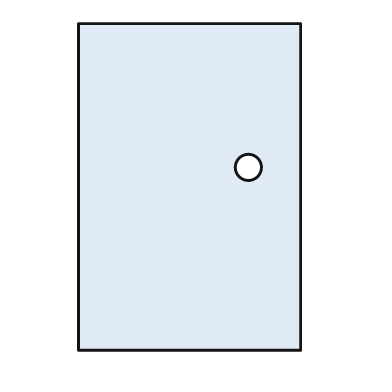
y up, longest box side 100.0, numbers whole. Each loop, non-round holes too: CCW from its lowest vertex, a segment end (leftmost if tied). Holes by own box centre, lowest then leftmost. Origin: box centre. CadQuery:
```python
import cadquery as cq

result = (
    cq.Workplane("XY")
    .moveTo(-34.0, -50.0)
    .lineTo(34.0, -50.0)
    .lineTo(34.0, 50.0)
    .lineTo(-34.0, 50.0)
    .close()
    .moveTo(18.0, 6.0)
    .circle(4.0)
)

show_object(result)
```